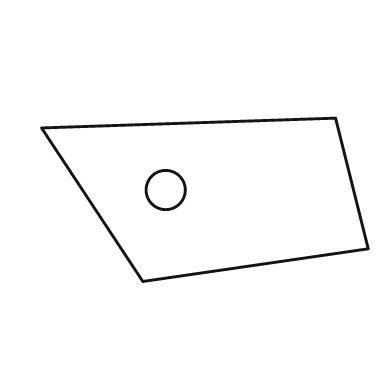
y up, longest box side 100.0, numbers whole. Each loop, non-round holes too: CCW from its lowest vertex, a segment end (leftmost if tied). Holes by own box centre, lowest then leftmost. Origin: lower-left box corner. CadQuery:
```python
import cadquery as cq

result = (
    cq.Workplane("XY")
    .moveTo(31.0, 0.0)
    .lineTo(100.0, 10.0)
    .lineTo(90.0, 50.0)
    .lineTo(0.0, 47.0)
    .close()
    .moveTo(38.0, 28.0)
    .circle(6.0)
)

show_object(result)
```